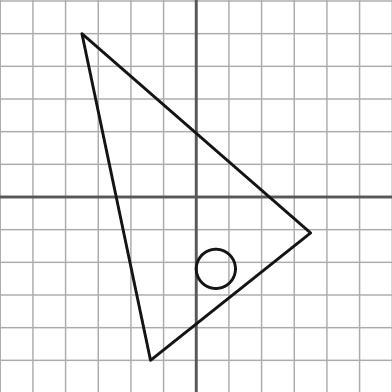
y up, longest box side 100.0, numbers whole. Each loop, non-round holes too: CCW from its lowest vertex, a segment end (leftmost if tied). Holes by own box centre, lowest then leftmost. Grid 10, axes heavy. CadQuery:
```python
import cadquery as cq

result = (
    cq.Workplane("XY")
    .moveTo(-14.0, -50.0)
    .lineTo(35.0, -11.0)
    .lineTo(-35.0, 50.0)
    .close()
    .moveTo(6.0, -22.0)
    .circle(6.0)
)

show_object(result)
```